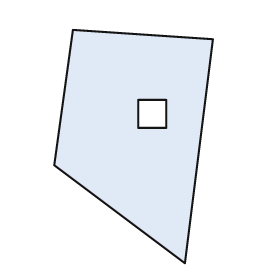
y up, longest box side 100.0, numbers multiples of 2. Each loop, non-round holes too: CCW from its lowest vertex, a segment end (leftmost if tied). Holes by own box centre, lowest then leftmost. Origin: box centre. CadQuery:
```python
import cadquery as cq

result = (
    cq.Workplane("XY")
    .moveTo(22.0, -50.0)
    .lineTo(34.0, 46.0)
    .lineTo(-26.0, 50.0)
    .lineTo(-34.0, -8.0)
    .close()
    .moveTo(2.0, 8.0)
    .lineTo(14.0, 8.0)
    .lineTo(14.0, 20.0)
    .lineTo(2.0, 20.0)
    .close()
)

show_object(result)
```